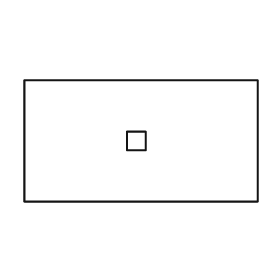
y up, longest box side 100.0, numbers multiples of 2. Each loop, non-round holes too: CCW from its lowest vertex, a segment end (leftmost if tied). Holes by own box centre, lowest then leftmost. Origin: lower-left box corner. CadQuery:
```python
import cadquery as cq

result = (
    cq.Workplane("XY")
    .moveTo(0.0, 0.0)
    .lineTo(100.0, 0.0)
    .lineTo(100.0, 52.0)
    .lineTo(0.0, 52.0)
    .close()
    .moveTo(44.0, 22.0)
    .lineTo(52.0, 22.0)
    .lineTo(52.0, 30.0)
    .lineTo(44.0, 30.0)
    .close()
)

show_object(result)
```